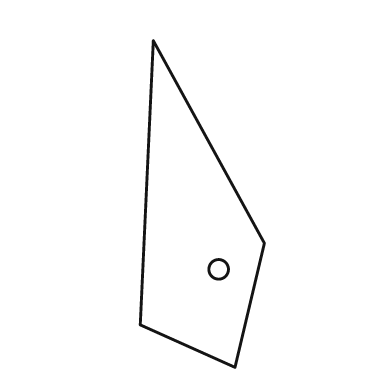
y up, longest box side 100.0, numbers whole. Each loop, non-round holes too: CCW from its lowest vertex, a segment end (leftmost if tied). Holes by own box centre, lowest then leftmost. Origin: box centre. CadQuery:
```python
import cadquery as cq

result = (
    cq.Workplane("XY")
    .moveTo(10.0, -50.0)
    .lineTo(19.0, -12.0)
    .lineTo(-15.0, 50.0)
    .lineTo(-19.0, -37.0)
    .close()
    .moveTo(5.0, -20.0)
    .circle(3.0)
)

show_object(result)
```